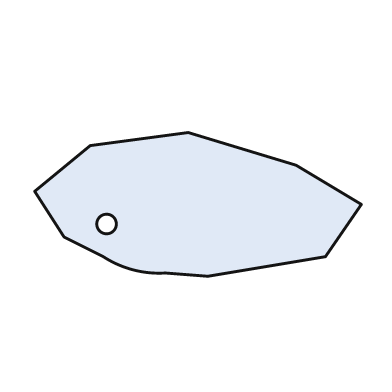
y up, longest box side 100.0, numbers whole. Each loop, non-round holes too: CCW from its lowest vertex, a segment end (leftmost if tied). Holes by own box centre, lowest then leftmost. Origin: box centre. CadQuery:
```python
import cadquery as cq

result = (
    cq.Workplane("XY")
    .moveTo(3.0, -22.0)
    .lineTo(39.0, -16.0)
    .lineTo(50.0, 0.0)
    .lineTo(30.0, 12.0)
    .lineTo(-3.0, 22.0)
    .lineTo(-33.0, 18.0)
    .lineTo(-50.0, 4.0)
    .lineTo(-41.0, -10.0)
    .lineTo(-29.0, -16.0)
    .threePointArc((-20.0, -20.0), (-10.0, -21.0))
    .close()
    .moveTo(-28.0, -6.0)
    .circle(3.0)
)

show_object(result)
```